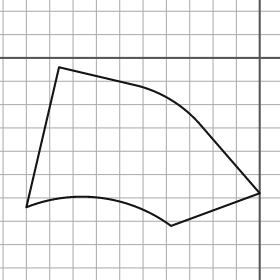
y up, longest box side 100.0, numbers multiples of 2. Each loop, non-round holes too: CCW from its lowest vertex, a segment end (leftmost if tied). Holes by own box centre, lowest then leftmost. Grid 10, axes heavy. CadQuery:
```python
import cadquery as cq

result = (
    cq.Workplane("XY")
    .moveTo(-38.0, -72.0)
    .lineTo(0.0, -58.0)
    .lineTo(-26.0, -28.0)
    .threePointArc((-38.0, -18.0), (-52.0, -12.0))
    .lineTo(-86.0, -4.0)
    .lineTo(-100.0, -64.0)
    .threePointArc((-68.0, -60.0), (-38.0, -72.0))
    .close()
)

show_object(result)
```